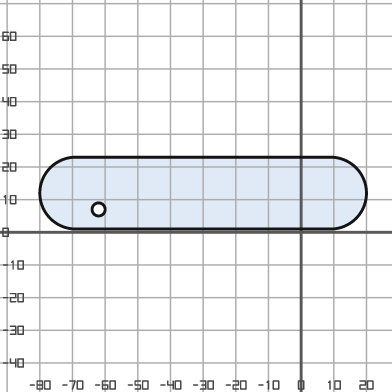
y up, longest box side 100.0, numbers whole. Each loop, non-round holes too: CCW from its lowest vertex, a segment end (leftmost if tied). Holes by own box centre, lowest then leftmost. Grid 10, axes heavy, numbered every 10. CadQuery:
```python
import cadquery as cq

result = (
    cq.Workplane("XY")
    .moveTo(-69.0, 1.0)
    .lineTo(9.0, 1.0)
    .threePointArc((20.0, 12.0), (9.0, 23.0))
    .lineTo(-69.0, 23.0)
    .threePointArc((-80.0, 12.0), (-69.0, 1.0))
    .close()
    .moveTo(-62.0, 7.0)
    .circle(2.0)
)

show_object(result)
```